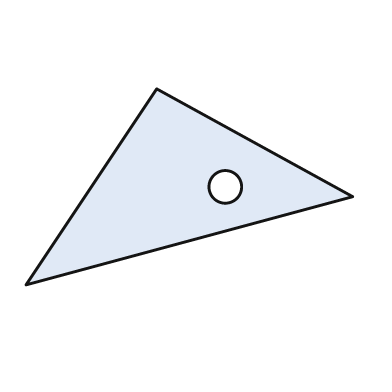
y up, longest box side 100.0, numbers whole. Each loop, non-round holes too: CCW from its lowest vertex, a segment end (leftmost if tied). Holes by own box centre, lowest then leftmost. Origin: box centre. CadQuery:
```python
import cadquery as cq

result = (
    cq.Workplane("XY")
    .moveTo(-50.0, -30.0)
    .lineTo(50.0, -3.0)
    .lineTo(-10.0, 30.0)
    .close()
    .moveTo(11.0, 0.0)
    .circle(5.0)
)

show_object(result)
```